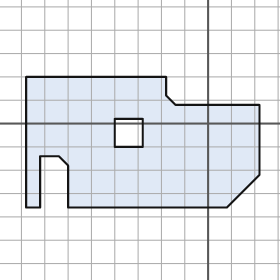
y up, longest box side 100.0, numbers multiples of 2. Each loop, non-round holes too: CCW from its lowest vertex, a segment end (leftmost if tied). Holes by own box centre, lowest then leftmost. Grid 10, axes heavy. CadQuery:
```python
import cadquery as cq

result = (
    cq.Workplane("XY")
    .moveTo(-78.0, -36.0)
    .lineTo(-72.0, -36.0)
    .lineTo(-72.0, -14.0)
    .lineTo(-64.0, -14.0)
    .lineTo(-60.0, -18.0)
    .lineTo(-60.0, -36.0)
    .lineTo(8.0, -36.0)
    .lineTo(22.0, -22.0)
    .lineTo(22.0, 8.0)
    .lineTo(-14.0, 8.0)
    .lineTo(-18.0, 12.0)
    .lineTo(-18.0, 20.0)
    .lineTo(-78.0, 20.0)
    .close()
    .moveTo(-40.0, -10.0)
    .lineTo(-28.0, -10.0)
    .lineTo(-28.0, 2.0)
    .lineTo(-40.0, 2.0)
    .close()
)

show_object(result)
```